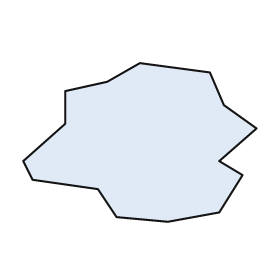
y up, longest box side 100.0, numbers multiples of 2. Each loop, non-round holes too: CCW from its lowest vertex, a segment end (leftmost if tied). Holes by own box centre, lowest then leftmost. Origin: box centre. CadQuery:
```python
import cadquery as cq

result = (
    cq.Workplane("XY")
    .moveTo(12.0, -34.0)
    .lineTo(34.0, -30.0)
    .lineTo(44.0, -14.0)
    .lineTo(34.0, -8.0)
    .lineTo(50.0, 6.0)
    .lineTo(36.0, 16.0)
    .lineTo(30.0, 30.0)
    .lineTo(0.0, 34.0)
    .lineTo(-14.0, 26.0)
    .lineTo(-32.0, 22.0)
    .lineTo(-32.0, 8.0)
    .lineTo(-50.0, -8.0)
    .lineTo(-46.0, -16.0)
    .lineTo(-18.0, -20.0)
    .lineTo(-10.0, -32.0)
    .close()
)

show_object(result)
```